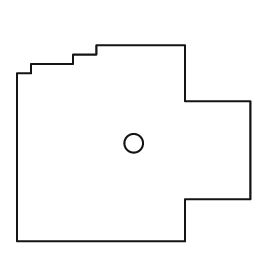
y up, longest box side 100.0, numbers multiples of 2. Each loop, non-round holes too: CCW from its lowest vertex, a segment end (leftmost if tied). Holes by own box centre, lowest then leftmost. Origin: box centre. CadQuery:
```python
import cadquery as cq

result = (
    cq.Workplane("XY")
    .moveTo(-50.0, -42.0)
    .lineTo(22.0, -42.0)
    .lineTo(22.0, -24.0)
    .lineTo(50.0, -24.0)
    .lineTo(50.0, 18.0)
    .lineTo(22.0, 18.0)
    .lineTo(22.0, 42.0)
    .lineTo(-16.0, 42.0)
    .lineTo(-16.0, 38.0)
    .lineTo(-26.0, 38.0)
    .lineTo(-26.0, 34.0)
    .lineTo(-44.0, 34.0)
    .lineTo(-44.0, 30.0)
    .lineTo(-50.0, 30.0)
    .close()
    .moveTo(0.0, 0.0)
    .circle(4.0)
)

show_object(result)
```